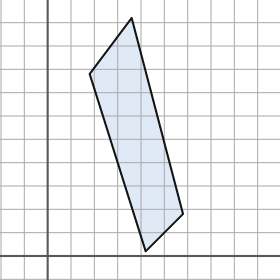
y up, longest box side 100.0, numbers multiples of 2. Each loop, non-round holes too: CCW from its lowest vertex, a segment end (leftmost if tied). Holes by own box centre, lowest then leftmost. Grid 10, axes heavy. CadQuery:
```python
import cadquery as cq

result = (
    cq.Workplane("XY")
    .moveTo(42.0, 2.0)
    .lineTo(58.0, 18.0)
    .lineTo(36.0, 102.0)
    .lineTo(18.0, 78.0)
    .close()
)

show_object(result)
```